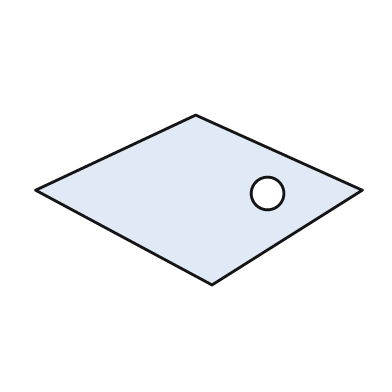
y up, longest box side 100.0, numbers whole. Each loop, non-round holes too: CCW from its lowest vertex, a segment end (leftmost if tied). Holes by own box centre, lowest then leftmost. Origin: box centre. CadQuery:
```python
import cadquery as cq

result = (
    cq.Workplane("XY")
    .moveTo(4.0, -26.0)
    .lineTo(50.0, 3.0)
    .lineTo(-1.0, 26.0)
    .lineTo(-50.0, 3.0)
    .close()
    .moveTo(21.0, 2.0)
    .circle(5.0)
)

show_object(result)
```